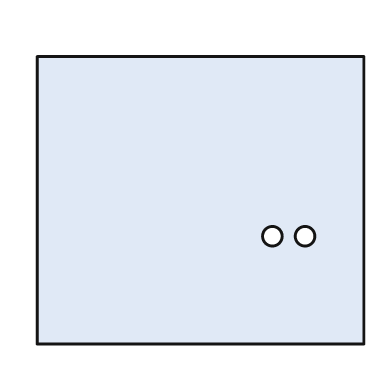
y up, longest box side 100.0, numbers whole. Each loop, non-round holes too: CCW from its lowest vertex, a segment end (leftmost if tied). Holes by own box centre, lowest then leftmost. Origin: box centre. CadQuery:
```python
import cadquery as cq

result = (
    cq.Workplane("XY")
    .moveTo(-50.0, -44.0)
    .lineTo(50.0, -44.0)
    .lineTo(50.0, 44.0)
    .lineTo(-50.0, 44.0)
    .close()
    .moveTo(22.0, -11.0)
    .circle(3.0)
    .moveTo(32.0, -11.0)
    .circle(3.0)
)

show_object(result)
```